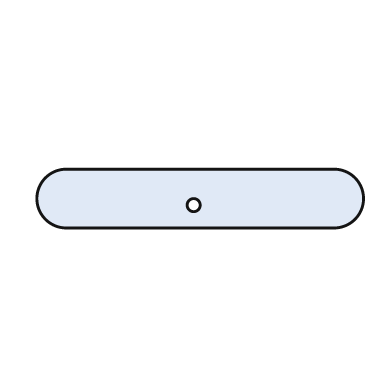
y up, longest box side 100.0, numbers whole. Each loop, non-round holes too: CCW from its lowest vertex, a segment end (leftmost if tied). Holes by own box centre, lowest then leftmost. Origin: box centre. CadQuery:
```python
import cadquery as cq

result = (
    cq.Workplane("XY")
    .moveTo(-41.0, -9.0)
    .lineTo(41.0, -9.0)
    .threePointArc((50.0, 0.0), (41.0, 9.0))
    .lineTo(-41.0, 9.0)
    .threePointArc((-50.0, 0.0), (-41.0, -9.0))
    .close()
    .moveTo(-2.0, -2.0)
    .circle(2.0)
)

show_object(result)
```